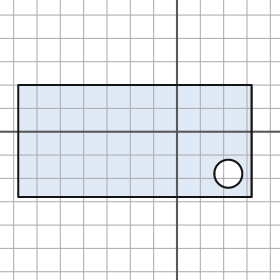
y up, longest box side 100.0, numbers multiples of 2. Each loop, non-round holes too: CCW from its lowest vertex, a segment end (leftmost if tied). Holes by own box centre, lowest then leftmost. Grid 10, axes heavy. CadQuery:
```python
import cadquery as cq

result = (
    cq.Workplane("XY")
    .moveTo(-68.0, -28.0)
    .lineTo(32.0, -28.0)
    .lineTo(32.0, 20.0)
    .lineTo(-68.0, 20.0)
    .close()
    .moveTo(22.0, -18.0)
    .circle(6.0)
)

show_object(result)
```